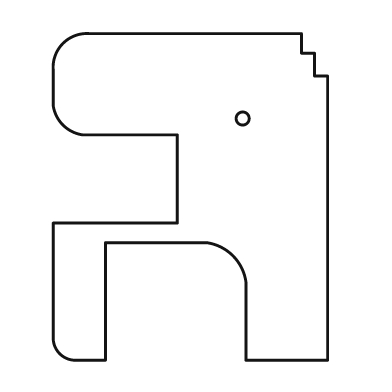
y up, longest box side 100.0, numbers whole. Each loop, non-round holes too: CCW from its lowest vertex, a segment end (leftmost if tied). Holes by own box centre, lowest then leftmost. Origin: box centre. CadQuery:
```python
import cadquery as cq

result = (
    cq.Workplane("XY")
    .moveTo(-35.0, -50.0)
    .lineTo(-26.0, -50.0)
    .lineTo(-26.0, -14.0)
    .lineTo(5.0, -14.0)
    .threePointArc((13.0, -18.0), (17.0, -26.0))
    .lineTo(17.0, -50.0)
    .lineTo(42.0, -50.0)
    .lineTo(42.0, 37.0)
    .lineTo(38.0, 37.0)
    .lineTo(38.0, 44.0)
    .lineTo(34.0, 44.0)
    .lineTo(34.0, 50.0)
    .lineTo(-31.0, 50.0)
    .threePointArc((-39.0, 47.0), (-42.0, 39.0))
    .lineTo(-42.0, 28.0)
    .threePointArc((-39.0, 22.0), (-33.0, 19.0))
    .lineTo(-4.0, 19.0)
    .lineTo(-4.0, -8.0)
    .lineTo(-42.0, -8.0)
    .lineTo(-42.0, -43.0)
    .threePointArc((-40.0, -48.0), (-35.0, -50.0))
    .close()
    .moveTo(16.0, 24.0)
    .circle(2.0)
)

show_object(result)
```